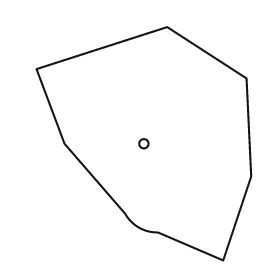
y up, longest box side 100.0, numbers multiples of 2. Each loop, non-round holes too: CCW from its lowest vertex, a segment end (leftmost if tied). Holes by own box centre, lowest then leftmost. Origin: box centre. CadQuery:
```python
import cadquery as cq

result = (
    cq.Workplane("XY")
    .moveTo(34.0, -50.0)
    .lineTo(46.0, -14.0)
    .lineTo(44.0, 28.0)
    .lineTo(10.0, 50.0)
    .lineTo(-46.0, 32.0)
    .lineTo(-34.0, 0.0)
    .lineTo(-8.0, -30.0)
    .threePointArc((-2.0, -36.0), (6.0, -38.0))
    .close()
    .moveTo(0.0, 0.0)
    .circle(2.0)
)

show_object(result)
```